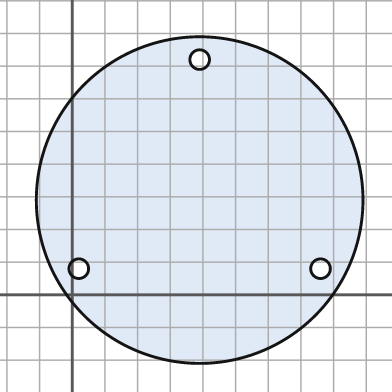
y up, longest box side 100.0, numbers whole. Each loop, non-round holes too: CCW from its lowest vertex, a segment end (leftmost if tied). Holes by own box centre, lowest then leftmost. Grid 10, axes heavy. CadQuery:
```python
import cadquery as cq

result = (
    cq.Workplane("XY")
    .moveTo(39.0, 29.0)
    .circle(50.0)
    .moveTo(2.0, 8.0)
    .circle(3.0)
    .moveTo(76.0, 8.0)
    .circle(3.0)
    .moveTo(39.0, 72.0)
    .circle(3.0)
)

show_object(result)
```